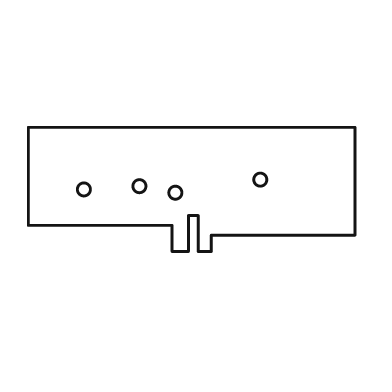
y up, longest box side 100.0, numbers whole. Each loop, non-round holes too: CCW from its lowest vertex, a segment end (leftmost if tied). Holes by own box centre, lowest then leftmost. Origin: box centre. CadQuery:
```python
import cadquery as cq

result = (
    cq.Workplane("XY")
    .moveTo(-6.0, -19.0)
    .lineTo(-1.0, -19.0)
    .lineTo(-1.0, -8.0)
    .lineTo(2.0, -8.0)
    .lineTo(2.0, -19.0)
    .lineTo(6.0, -19.0)
    .lineTo(6.0, -14.0)
    .lineTo(50.0, -14.0)
    .lineTo(50.0, 19.0)
    .lineTo(-50.0, 19.0)
    .lineTo(-50.0, -11.0)
    .lineTo(-6.0, -11.0)
    .close()
    .moveTo(-5.0, -1.0)
    .circle(2.0)
    .moveTo(-33.0, 0.0)
    .circle(2.0)
    .moveTo(-16.0, 1.0)
    .circle(2.0)
    .moveTo(21.0, 3.0)
    .circle(2.0)
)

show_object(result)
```